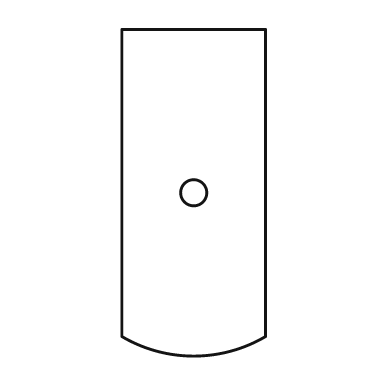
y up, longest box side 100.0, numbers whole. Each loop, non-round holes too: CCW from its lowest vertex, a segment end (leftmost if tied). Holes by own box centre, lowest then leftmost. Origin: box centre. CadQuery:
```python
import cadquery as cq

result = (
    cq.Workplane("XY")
    .moveTo(-22.0, -44.0)
    .threePointArc((0.0, -50.0), (22.0, -44.0))
    .lineTo(22.0, 50.0)
    .lineTo(-22.0, 50.0)
    .close()
    .moveTo(0.0, 0.0)
    .circle(4.0)
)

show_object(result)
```